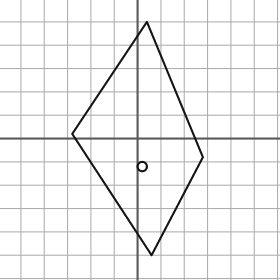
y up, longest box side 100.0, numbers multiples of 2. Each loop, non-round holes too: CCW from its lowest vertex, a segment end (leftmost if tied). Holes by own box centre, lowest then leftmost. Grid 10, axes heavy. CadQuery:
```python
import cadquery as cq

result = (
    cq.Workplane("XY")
    .moveTo(6.0, -50.0)
    .lineTo(28.0, -8.0)
    .lineTo(4.0, 50.0)
    .lineTo(-28.0, 2.0)
    .close()
    .moveTo(2.0, -12.0)
    .circle(2.0)
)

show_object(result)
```